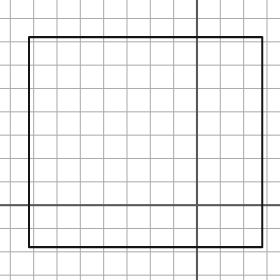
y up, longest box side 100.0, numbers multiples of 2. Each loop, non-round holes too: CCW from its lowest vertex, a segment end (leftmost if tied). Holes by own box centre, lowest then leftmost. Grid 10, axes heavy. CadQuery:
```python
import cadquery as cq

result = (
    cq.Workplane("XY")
    .moveTo(-72.0, -18.0)
    .lineTo(28.0, -18.0)
    .lineTo(28.0, 72.0)
    .lineTo(-72.0, 72.0)
    .close()
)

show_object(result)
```